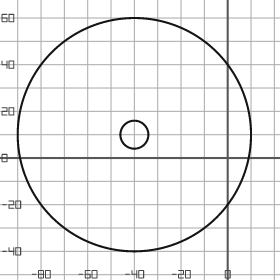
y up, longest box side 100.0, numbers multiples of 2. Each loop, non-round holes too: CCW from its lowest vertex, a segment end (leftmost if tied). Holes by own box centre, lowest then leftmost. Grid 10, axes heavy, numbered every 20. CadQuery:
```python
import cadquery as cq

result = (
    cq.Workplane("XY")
    .moveTo(-40.0, 10.0)
    .circle(50.0)
    .moveTo(-40.0, 10.0)
    .circle(6.0)
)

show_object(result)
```